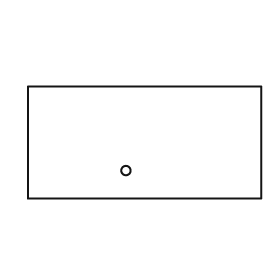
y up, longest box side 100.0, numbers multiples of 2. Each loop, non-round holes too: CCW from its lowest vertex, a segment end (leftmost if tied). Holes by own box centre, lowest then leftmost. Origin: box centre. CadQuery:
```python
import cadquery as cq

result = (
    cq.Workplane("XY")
    .moveTo(-50.0, -24.0)
    .lineTo(50.0, -24.0)
    .lineTo(50.0, 24.0)
    .lineTo(-50.0, 24.0)
    .close()
    .moveTo(-8.0, -12.0)
    .circle(2.0)
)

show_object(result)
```